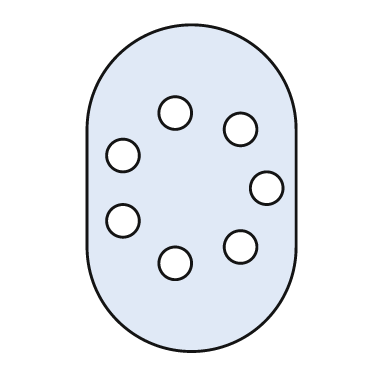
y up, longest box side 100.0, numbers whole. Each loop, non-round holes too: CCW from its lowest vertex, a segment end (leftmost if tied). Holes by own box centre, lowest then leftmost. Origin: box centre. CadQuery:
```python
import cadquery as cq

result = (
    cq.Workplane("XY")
    .moveTo(-32.0, -18.0)
    .threePointArc((0.0, -50.0), (32.0, -18.0))
    .lineTo(32.0, 18.0)
    .threePointArc((0.0, 50.0), (-32.0, 18.0))
    .close()
    .moveTo(-5.0, -23.0)
    .circle(5.0)
    .moveTo(15.0, -18.0)
    .circle(5.0)
    .moveTo(-21.0, -10.0)
    .circle(5.0)
    .moveTo(23.0, 0.0)
    .circle(5.0)
    .moveTo(-21.0, 10.0)
    .circle(5.0)
    .moveTo(15.0, 18.0)
    .circle(5.0)
    .moveTo(-5.0, 23.0)
    .circle(5.0)
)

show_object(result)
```